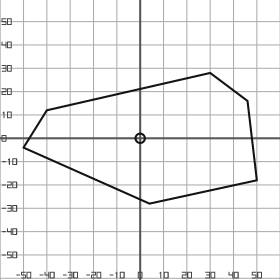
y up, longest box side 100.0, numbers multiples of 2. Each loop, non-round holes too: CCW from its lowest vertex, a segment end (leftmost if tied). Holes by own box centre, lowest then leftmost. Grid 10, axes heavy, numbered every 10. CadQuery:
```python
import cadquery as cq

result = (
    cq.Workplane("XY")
    .moveTo(4.0, -28.0)
    .lineTo(50.0, -18.0)
    .lineTo(46.0, 16.0)
    .lineTo(30.0, 28.0)
    .lineTo(-40.0, 12.0)
    .lineTo(-50.0, -4.0)
    .close()
    .moveTo(0.0, 0.0)
    .circle(2.0)
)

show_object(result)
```